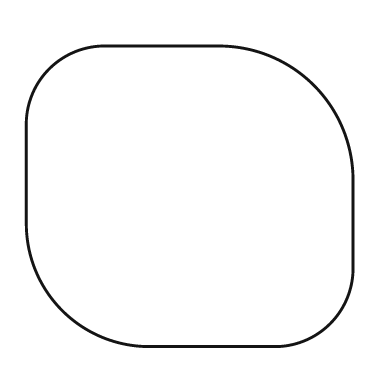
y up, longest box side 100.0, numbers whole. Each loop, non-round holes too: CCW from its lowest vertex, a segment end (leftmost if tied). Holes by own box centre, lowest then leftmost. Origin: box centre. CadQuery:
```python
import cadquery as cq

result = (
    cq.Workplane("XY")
    .moveTo(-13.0, -46.0)
    .lineTo(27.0, -46.0)
    .threePointArc((43.0, -39.0), (50.0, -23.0))
    .lineTo(50.0, 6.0)
    .threePointArc((38.0, 34.0), (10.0, 46.0))
    .lineTo(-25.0, 46.0)
    .threePointArc((-43.0, 39.0), (-50.0, 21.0))
    .lineTo(-50.0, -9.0)
    .threePointArc((-39.0, -35.0), (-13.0, -46.0))
    .close()
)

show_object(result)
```